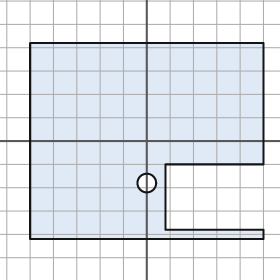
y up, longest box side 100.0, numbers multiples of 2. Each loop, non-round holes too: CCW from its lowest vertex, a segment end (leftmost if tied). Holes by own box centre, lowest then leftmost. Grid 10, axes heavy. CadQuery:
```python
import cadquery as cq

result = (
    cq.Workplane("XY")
    .moveTo(-50.0, -42.0)
    .lineTo(50.0, -42.0)
    .lineTo(50.0, -38.0)
    .lineTo(8.0, -38.0)
    .lineTo(8.0, -10.0)
    .lineTo(50.0, -10.0)
    .lineTo(50.0, 42.0)
    .lineTo(-50.0, 42.0)
    .close()
    .moveTo(0.0, -18.0)
    .circle(4.0)
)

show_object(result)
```